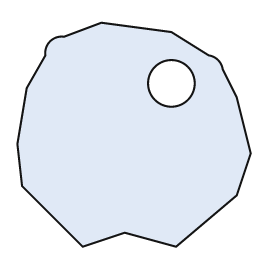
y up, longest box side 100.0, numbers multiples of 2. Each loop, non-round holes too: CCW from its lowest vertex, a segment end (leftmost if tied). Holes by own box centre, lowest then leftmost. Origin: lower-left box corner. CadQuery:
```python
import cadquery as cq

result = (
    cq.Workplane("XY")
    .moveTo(28.0, 0.0)
    .lineTo(46.0, 6.0)
    .lineTo(68.0, 0.0)
    .lineTo(94.0, 22.0)
    .lineTo(100.0, 40.0)
    .lineTo(94.0, 64.0)
    .lineTo(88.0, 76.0)
    .threePointArc((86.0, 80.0), (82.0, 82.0))
    .lineTo(66.0, 92.0)
    .lineTo(36.0, 96.0)
    .lineTo(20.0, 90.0)
    .threePointArc((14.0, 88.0), (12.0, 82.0))
    .lineTo(4.0, 68.0)
    .lineTo(0.0, 44.0)
    .lineTo(2.0, 26.0)
    .close()
    .moveTo(66.0, 70.0)
    .circle(10.0)
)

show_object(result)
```